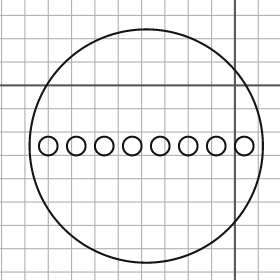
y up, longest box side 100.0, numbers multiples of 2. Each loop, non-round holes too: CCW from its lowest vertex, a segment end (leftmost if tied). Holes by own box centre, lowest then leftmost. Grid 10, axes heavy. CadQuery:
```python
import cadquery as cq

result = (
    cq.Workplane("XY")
    .moveTo(-38.0, -26.0)
    .circle(50.0)
    .moveTo(-80.0, -26.0)
    .circle(4.0)
    .moveTo(-68.0, -26.0)
    .circle(4.0)
    .moveTo(-56.0, -26.0)
    .circle(4.0)
    .moveTo(-44.0, -26.0)
    .circle(4.0)
    .moveTo(-32.0, -26.0)
    .circle(4.0)
    .moveTo(-20.0, -26.0)
    .circle(4.0)
    .moveTo(-8.0, -26.0)
    .circle(4.0)
    .moveTo(4.0, -26.0)
    .circle(4.0)
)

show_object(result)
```